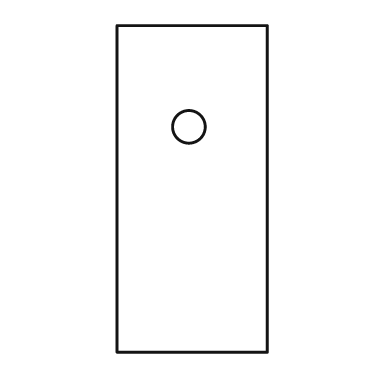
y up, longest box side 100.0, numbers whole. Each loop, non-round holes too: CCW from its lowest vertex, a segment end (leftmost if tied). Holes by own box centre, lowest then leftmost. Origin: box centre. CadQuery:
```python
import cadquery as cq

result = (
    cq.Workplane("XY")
    .moveTo(-23.0, -50.0)
    .lineTo(23.0, -50.0)
    .lineTo(23.0, 50.0)
    .lineTo(-23.0, 50.0)
    .close()
    .moveTo(-1.0, 19.0)
    .circle(5.0)
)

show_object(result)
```